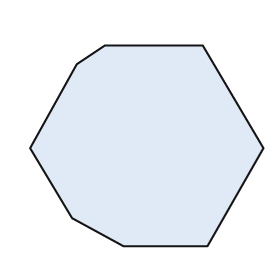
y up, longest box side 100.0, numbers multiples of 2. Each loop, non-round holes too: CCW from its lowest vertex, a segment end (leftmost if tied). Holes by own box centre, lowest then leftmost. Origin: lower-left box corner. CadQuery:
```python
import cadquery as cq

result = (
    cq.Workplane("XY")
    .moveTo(40.0, 0.0)
    .lineTo(76.0, 0.0)
    .lineTo(100.0, 42.0)
    .lineTo(74.0, 86.0)
    .lineTo(32.0, 86.0)
    .lineTo(20.0, 78.0)
    .lineTo(0.0, 42.0)
    .lineTo(18.0, 12.0)
    .close()
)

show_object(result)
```